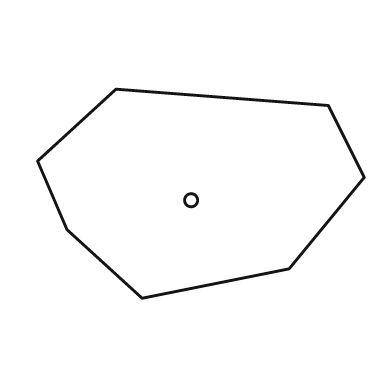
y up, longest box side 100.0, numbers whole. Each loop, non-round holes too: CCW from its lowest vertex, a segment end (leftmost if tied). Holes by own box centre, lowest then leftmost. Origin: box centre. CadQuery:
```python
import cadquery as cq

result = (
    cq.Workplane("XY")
    .moveTo(-18.0, -32.0)
    .lineTo(27.0, -23.0)
    .lineTo(50.0, 5.0)
    .lineTo(39.0, 27.0)
    .lineTo(-26.0, 32.0)
    .lineTo(-50.0, 10.0)
    .lineTo(-41.0, -11.0)
    .close()
    .moveTo(-3.0, -2.0)
    .circle(2.0)
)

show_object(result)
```